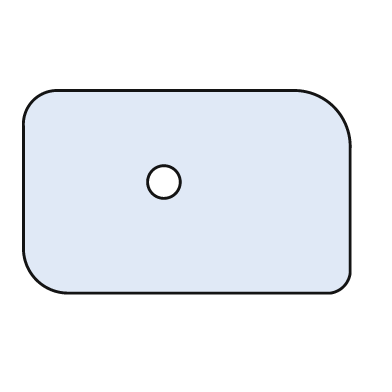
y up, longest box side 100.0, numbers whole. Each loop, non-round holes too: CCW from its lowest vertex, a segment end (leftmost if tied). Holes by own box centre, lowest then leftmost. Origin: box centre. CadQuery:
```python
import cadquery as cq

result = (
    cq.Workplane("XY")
    .moveTo(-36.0, -31.0)
    .lineTo(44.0, -31.0)
    .threePointArc((48.0, -29.0), (50.0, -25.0))
    .lineTo(50.0, 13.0)
    .threePointArc((45.0, 26.0), (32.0, 31.0))
    .lineTo(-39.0, 31.0)
    .threePointArc((-47.0, 28.0), (-50.0, 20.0))
    .lineTo(-50.0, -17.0)
    .threePointArc((-46.0, -27.0), (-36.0, -31.0))
    .close()
    .moveTo(-7.0, 3.0)
    .circle(5.0)
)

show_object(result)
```